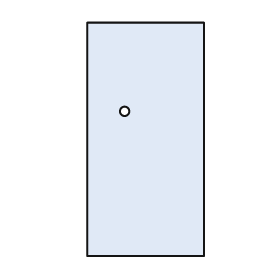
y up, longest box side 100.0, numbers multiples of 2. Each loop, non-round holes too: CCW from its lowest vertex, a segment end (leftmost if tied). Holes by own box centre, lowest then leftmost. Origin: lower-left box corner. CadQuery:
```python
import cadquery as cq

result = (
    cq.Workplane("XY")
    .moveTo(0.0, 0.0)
    .lineTo(50.0, 0.0)
    .lineTo(50.0, 100.0)
    .lineTo(0.0, 100.0)
    .close()
    .moveTo(16.0, 62.0)
    .circle(2.0)
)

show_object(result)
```